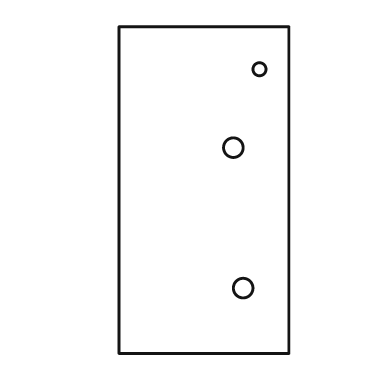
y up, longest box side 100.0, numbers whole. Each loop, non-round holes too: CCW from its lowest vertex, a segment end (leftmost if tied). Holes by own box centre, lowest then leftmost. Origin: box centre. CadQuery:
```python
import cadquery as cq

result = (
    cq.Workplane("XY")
    .moveTo(-26.0, -50.0)
    .lineTo(26.0, -50.0)
    .lineTo(26.0, 50.0)
    .lineTo(-26.0, 50.0)
    .close()
    .moveTo(12.0, -30.0)
    .circle(3.0)
    .moveTo(9.0, 13.0)
    .circle(3.0)
    .moveTo(17.0, 37.0)
    .circle(2.0)
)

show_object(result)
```